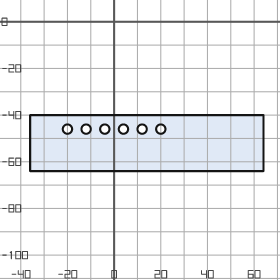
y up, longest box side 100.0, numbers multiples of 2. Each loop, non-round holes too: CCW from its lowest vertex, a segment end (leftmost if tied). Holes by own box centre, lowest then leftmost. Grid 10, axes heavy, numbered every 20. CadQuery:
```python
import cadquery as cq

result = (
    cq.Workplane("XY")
    .moveTo(-36.0, -64.0)
    .lineTo(64.0, -64.0)
    .lineTo(64.0, -40.0)
    .lineTo(-36.0, -40.0)
    .close()
    .moveTo(-20.0, -46.0)
    .circle(2.0)
    .moveTo(-12.0, -46.0)
    .circle(2.0)
    .moveTo(-4.0, -46.0)
    .circle(2.0)
    .moveTo(4.0, -46.0)
    .circle(2.0)
    .moveTo(12.0, -46.0)
    .circle(2.0)
    .moveTo(20.0, -46.0)
    .circle(2.0)
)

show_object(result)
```